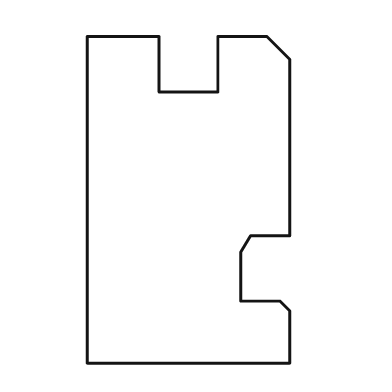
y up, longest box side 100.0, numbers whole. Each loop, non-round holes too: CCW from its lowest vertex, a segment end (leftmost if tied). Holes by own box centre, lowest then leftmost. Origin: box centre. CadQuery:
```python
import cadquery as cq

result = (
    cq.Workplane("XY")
    .moveTo(-31.0, -50.0)
    .lineTo(31.0, -50.0)
    .lineTo(31.0, -34.0)
    .lineTo(28.0, -31.0)
    .lineTo(16.0, -31.0)
    .lineTo(16.0, -16.0)
    .lineTo(19.0, -11.0)
    .lineTo(31.0, -11.0)
    .lineTo(31.0, 43.0)
    .lineTo(24.0, 50.0)
    .lineTo(9.0, 50.0)
    .lineTo(9.0, 33.0)
    .lineTo(-9.0, 33.0)
    .lineTo(-9.0, 50.0)
    .lineTo(-31.0, 50.0)
    .close()
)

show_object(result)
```